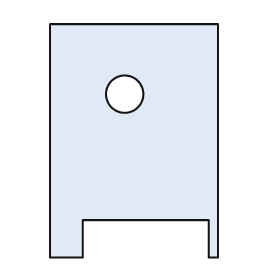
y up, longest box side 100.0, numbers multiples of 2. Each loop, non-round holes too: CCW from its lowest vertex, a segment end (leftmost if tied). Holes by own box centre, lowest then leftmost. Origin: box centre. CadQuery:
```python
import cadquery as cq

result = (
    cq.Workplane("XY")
    .moveTo(-36.0, -50.0)
    .lineTo(-22.0, -50.0)
    .lineTo(-22.0, -34.0)
    .lineTo(32.0, -34.0)
    .lineTo(32.0, -50.0)
    .lineTo(36.0, -50.0)
    .lineTo(36.0, 50.0)
    .lineTo(-36.0, 50.0)
    .close()
    .moveTo(-4.0, 20.0)
    .circle(8.0)
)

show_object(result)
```